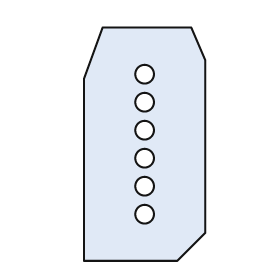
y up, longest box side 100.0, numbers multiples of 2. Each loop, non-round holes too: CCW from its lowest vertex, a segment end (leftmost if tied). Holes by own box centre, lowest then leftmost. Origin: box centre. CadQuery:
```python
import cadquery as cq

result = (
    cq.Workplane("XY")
    .moveTo(-26.0, -50.0)
    .lineTo(14.0, -50.0)
    .lineTo(26.0, -38.0)
    .lineTo(26.0, 36.0)
    .lineTo(20.0, 50.0)
    .lineTo(-18.0, 50.0)
    .lineTo(-26.0, 28.0)
    .close()
    .moveTo(0.0, -30.0)
    .circle(4.0)
    .moveTo(0.0, -18.0)
    .circle(4.0)
    .moveTo(0.0, -6.0)
    .circle(4.0)
    .moveTo(0.0, 6.0)
    .circle(4.0)
    .moveTo(0.0, 18.0)
    .circle(4.0)
    .moveTo(0.0, 30.0)
    .circle(4.0)
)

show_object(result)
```